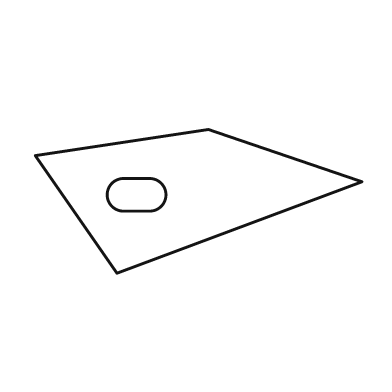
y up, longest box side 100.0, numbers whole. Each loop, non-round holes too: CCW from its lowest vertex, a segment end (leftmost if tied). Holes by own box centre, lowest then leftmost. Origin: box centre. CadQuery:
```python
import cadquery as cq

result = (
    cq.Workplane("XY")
    .moveTo(-25.0, -22.0)
    .lineTo(50.0, 6.0)
    .lineTo(3.0, 22.0)
    .lineTo(-50.0, 14.0)
    .close()
    .moveTo(-23.0, -3.0)
    .lineTo(-15.0, -3.0)
    .threePointArc((-10.0, 2.0), (-15.0, 7.0))
    .lineTo(-23.0, 7.0)
    .threePointArc((-28.0, 2.0), (-23.0, -3.0))
    .close()
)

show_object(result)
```